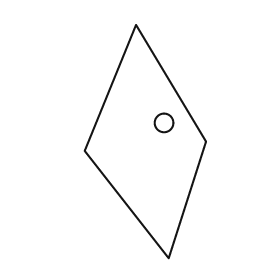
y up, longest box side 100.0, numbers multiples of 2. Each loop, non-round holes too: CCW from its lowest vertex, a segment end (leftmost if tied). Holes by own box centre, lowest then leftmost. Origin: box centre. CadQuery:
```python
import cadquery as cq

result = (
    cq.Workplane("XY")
    .moveTo(10.0, -50.0)
    .lineTo(26.0, 0.0)
    .lineTo(-4.0, 50.0)
    .lineTo(-26.0, -4.0)
    .close()
    .moveTo(8.0, 8.0)
    .circle(4.0)
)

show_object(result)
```